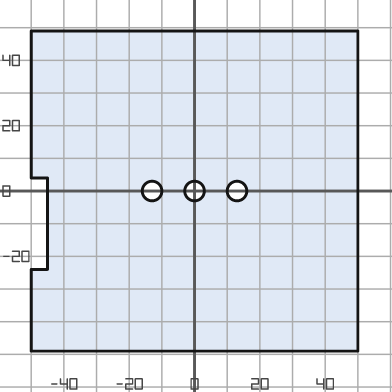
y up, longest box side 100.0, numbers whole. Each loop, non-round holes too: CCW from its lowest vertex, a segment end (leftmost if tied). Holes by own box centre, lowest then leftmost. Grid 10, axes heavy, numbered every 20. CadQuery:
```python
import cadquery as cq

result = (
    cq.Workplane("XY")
    .moveTo(-50.0, -49.0)
    .lineTo(50.0, -49.0)
    .lineTo(50.0, 49.0)
    .lineTo(-50.0, 49.0)
    .lineTo(-50.0, 4.0)
    .lineTo(-45.0, 4.0)
    .lineTo(-45.0, -24.0)
    .lineTo(-50.0, -24.0)
    .close()
    .moveTo(-13.0, 0.0)
    .circle(3.0)
    .moveTo(0.0, 0.0)
    .circle(3.0)
    .moveTo(13.0, 0.0)
    .circle(3.0)
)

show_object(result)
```